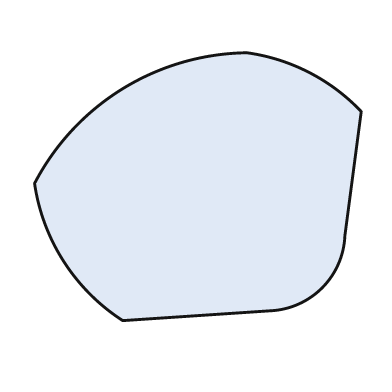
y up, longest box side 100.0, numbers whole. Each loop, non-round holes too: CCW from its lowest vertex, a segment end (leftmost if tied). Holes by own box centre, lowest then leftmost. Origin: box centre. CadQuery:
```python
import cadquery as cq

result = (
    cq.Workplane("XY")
    .moveTo(-23.0, -41.0)
    .lineTo(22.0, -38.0)
    .threePointArc((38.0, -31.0), (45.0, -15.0))
    .lineTo(50.0, 23.0)
    .threePointArc((34.0, 35.0), (15.0, 41.0))
    .threePointArc((-23.0, 30.0), (-50.0, 1.0))
    .threePointArc((-41.0, -23.0), (-23.0, -41.0))
    .close()
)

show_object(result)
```